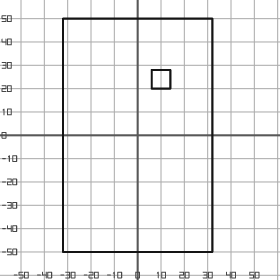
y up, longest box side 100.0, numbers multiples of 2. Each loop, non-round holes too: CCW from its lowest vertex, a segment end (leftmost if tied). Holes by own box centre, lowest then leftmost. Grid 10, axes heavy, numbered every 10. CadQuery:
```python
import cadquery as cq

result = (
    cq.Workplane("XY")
    .moveTo(-32.0, -50.0)
    .lineTo(32.0, -50.0)
    .lineTo(32.0, 50.0)
    .lineTo(-32.0, 50.0)
    .close()
    .moveTo(6.0, 20.0)
    .lineTo(14.0, 20.0)
    .lineTo(14.0, 28.0)
    .lineTo(6.0, 28.0)
    .close()
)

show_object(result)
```